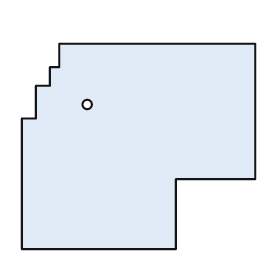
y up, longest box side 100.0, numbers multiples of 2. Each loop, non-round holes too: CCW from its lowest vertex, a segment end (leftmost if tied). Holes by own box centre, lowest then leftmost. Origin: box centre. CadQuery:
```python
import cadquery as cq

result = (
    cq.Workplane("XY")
    .moveTo(-50.0, -44.0)
    .lineTo(16.0, -44.0)
    .lineTo(16.0, -14.0)
    .lineTo(50.0, -14.0)
    .lineTo(50.0, 44.0)
    .lineTo(-34.0, 44.0)
    .lineTo(-34.0, 34.0)
    .lineTo(-38.0, 34.0)
    .lineTo(-38.0, 26.0)
    .lineTo(-44.0, 26.0)
    .lineTo(-44.0, 12.0)
    .lineTo(-50.0, 12.0)
    .close()
    .moveTo(-22.0, 18.0)
    .circle(2.0)
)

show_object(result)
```